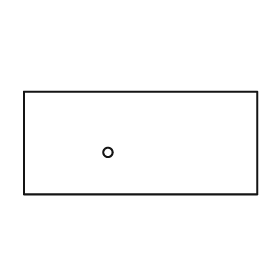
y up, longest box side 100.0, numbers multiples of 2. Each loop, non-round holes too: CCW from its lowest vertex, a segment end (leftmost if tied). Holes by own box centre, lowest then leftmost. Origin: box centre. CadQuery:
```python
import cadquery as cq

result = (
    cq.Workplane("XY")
    .moveTo(-50.0, -22.0)
    .lineTo(50.0, -22.0)
    .lineTo(50.0, 22.0)
    .lineTo(-50.0, 22.0)
    .close()
    .moveTo(-14.0, -4.0)
    .circle(2.0)
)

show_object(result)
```